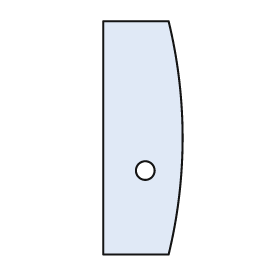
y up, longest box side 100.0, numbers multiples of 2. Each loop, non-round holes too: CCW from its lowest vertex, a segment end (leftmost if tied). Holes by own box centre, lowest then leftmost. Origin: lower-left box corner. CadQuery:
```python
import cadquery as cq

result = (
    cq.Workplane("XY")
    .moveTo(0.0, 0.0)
    .lineTo(28.0, 0.0)
    .threePointArc((34.0, 50.0), (28.0, 100.0))
    .lineTo(0.0, 100.0)
    .close()
    .moveTo(18.0, 36.0)
    .circle(4.0)
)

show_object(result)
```